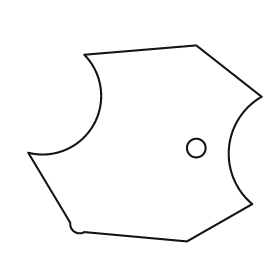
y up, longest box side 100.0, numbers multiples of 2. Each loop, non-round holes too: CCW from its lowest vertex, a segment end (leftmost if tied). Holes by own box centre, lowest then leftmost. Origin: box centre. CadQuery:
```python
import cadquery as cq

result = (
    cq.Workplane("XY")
    .moveTo(18.0, -42.0)
    .lineTo(46.0, -26.0)
    .threePointArc((36.0, -2.0), (50.0, 20.0))
    .lineTo(22.0, 42.0)
    .lineTo(-26.0, 38.0)
    .threePointArc((-22.0, 8.0), (-50.0, -4.0))
    .lineTo(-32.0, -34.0)
    .threePointArc((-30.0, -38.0), (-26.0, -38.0))
    .close()
    .moveTo(22.0, -2.0)
    .circle(4.0)
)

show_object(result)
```